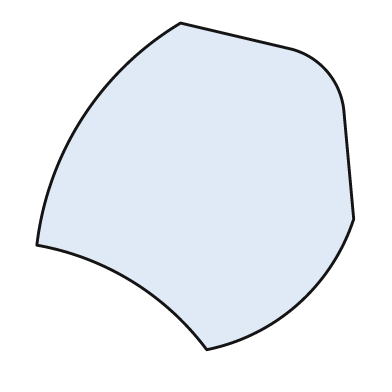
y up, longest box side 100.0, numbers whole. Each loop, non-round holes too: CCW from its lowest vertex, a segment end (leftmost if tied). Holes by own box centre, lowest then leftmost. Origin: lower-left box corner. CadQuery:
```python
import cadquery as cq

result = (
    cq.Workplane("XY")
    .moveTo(52.0, 0.0)
    .threePointArc((80.0, 14.0), (97.0, 40.0))
    .lineTo(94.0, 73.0)
    .threePointArc((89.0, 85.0), (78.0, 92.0))
    .lineTo(44.0, 100.0)
    .threePointArc((14.0, 71.0), (0.0, 32.0))
    .threePointArc((29.0, 21.0), (52.0, 0.0))
    .close()
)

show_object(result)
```